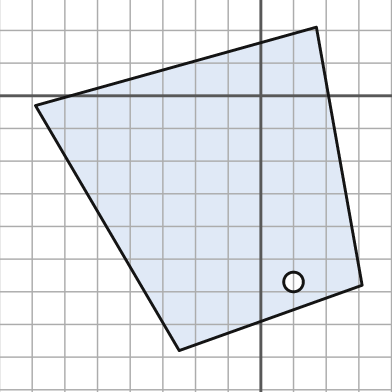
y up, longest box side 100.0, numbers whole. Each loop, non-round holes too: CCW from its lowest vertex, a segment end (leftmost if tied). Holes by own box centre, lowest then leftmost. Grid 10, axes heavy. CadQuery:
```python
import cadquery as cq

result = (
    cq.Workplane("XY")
    .moveTo(-25.0, -78.0)
    .lineTo(31.0, -58.0)
    .lineTo(17.0, 21.0)
    .lineTo(-69.0, -3.0)
    .close()
    .moveTo(10.0, -57.0)
    .circle(3.0)
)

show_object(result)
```